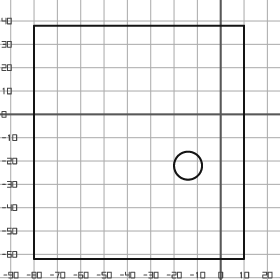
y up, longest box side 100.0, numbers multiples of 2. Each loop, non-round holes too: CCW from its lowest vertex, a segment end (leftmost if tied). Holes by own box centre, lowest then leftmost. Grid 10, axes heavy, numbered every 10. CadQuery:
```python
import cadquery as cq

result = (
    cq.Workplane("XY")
    .moveTo(-80.0, -62.0)
    .lineTo(10.0, -62.0)
    .lineTo(10.0, 38.0)
    .lineTo(-80.0, 38.0)
    .close()
    .moveTo(-14.0, -22.0)
    .circle(6.0)
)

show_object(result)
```